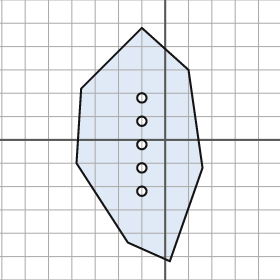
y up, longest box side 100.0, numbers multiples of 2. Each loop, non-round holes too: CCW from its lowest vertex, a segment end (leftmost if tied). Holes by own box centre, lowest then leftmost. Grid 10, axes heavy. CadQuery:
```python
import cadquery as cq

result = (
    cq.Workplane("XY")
    .moveTo(2.0, -52.0)
    .lineTo(16.0, -12.0)
    .lineTo(10.0, 30.0)
    .lineTo(-10.0, 48.0)
    .lineTo(-36.0, 22.0)
    .lineTo(-38.0, -10.0)
    .lineTo(-16.0, -44.0)
    .close()
    .moveTo(-10.0, -22.0)
    .circle(2.0)
    .moveTo(-10.0, -12.0)
    .circle(2.0)
    .moveTo(-10.0, -2.0)
    .circle(2.0)
    .moveTo(-10.0, 8.0)
    .circle(2.0)
    .moveTo(-10.0, 18.0)
    .circle(2.0)
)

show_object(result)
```